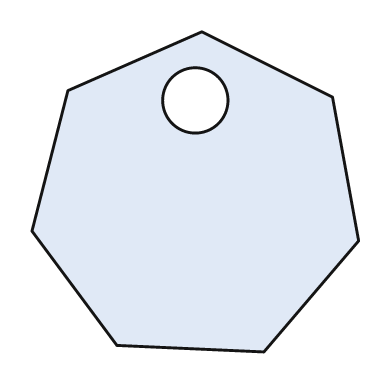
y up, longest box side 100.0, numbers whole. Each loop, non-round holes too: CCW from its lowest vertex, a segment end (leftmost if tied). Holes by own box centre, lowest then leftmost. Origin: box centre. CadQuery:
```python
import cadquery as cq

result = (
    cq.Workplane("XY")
    .moveTo(21.0, -49.0)
    .lineTo(50.0, -15.0)
    .lineTo(42.0, 29.0)
    .lineTo(2.0, 49.0)
    .lineTo(-39.0, 31.0)
    .lineTo(-50.0, -12.0)
    .lineTo(-24.0, -47.0)
    .close()
    .moveTo(0.0, 28.0)
    .circle(10.0)
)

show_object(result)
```